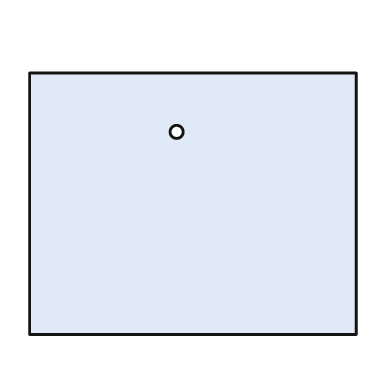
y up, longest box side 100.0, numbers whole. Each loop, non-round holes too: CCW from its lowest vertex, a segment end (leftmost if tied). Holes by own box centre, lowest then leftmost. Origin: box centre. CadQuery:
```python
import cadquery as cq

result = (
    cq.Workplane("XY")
    .moveTo(-50.0, -40.0)
    .lineTo(50.0, -40.0)
    .lineTo(50.0, 40.0)
    .lineTo(-50.0, 40.0)
    .close()
    .moveTo(-5.0, 22.0)
    .circle(2.0)
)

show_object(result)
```